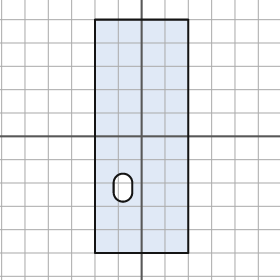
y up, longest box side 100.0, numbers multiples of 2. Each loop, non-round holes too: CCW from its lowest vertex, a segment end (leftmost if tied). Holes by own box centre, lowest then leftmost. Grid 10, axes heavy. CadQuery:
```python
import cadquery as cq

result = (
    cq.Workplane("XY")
    .moveTo(-20.0, -50.0)
    .lineTo(20.0, -50.0)
    .lineTo(20.0, 50.0)
    .lineTo(-20.0, 50.0)
    .close()
    .moveTo(-12.0, -24.0)
    .threePointArc((-8.0, -28.0), (-4.0, -24.0))
    .lineTo(-4.0, -20.0)
    .threePointArc((-8.0, -16.0), (-12.0, -20.0))
    .close()
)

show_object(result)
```